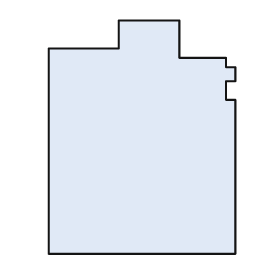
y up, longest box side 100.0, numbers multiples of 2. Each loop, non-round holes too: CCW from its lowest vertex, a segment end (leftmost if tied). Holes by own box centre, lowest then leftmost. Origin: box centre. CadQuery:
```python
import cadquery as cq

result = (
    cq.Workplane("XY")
    .moveTo(-40.0, -50.0)
    .lineTo(40.0, -50.0)
    .lineTo(40.0, 16.0)
    .lineTo(36.0, 16.0)
    .lineTo(36.0, 24.0)
    .lineTo(40.0, 24.0)
    .lineTo(40.0, 30.0)
    .lineTo(36.0, 30.0)
    .lineTo(36.0, 34.0)
    .lineTo(16.0, 34.0)
    .lineTo(16.0, 50.0)
    .lineTo(-10.0, 50.0)
    .lineTo(-10.0, 38.0)
    .lineTo(-40.0, 38.0)
    .close()
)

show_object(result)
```